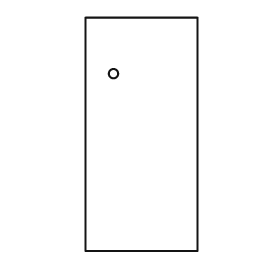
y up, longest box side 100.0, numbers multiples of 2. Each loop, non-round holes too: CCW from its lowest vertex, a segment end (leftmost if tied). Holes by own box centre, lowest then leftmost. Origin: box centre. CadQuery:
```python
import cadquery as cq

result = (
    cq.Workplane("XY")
    .moveTo(-24.0, -50.0)
    .lineTo(24.0, -50.0)
    .lineTo(24.0, 50.0)
    .lineTo(-24.0, 50.0)
    .close()
    .moveTo(-12.0, 26.0)
    .circle(2.0)
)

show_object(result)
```